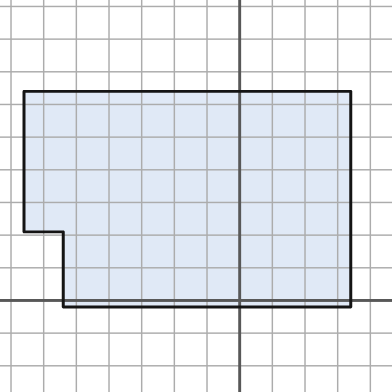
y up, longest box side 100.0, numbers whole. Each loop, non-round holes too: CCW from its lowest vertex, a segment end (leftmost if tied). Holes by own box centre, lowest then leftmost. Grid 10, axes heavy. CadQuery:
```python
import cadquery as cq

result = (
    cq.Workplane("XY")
    .moveTo(-54.0, -2.0)
    .lineTo(34.0, -2.0)
    .lineTo(34.0, 64.0)
    .lineTo(-66.0, 64.0)
    .lineTo(-66.0, 21.0)
    .lineTo(-54.0, 21.0)
    .close()
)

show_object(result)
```